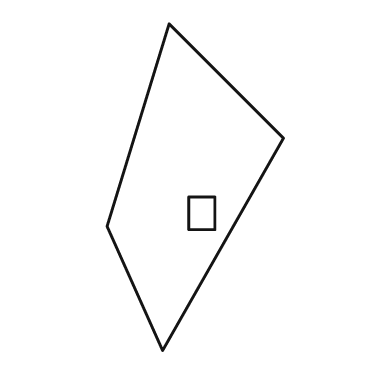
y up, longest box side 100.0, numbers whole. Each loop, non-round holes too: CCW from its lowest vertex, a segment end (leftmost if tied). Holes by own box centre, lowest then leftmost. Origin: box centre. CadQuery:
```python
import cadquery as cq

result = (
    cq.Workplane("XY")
    .moveTo(-10.0, -50.0)
    .lineTo(27.0, 15.0)
    .lineTo(-8.0, 50.0)
    .lineTo(-27.0, -12.0)
    .close()
    .moveTo(-2.0, -13.0)
    .lineTo(6.0, -13.0)
    .lineTo(6.0, -3.0)
    .lineTo(-2.0, -3.0)
    .close()
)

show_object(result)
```